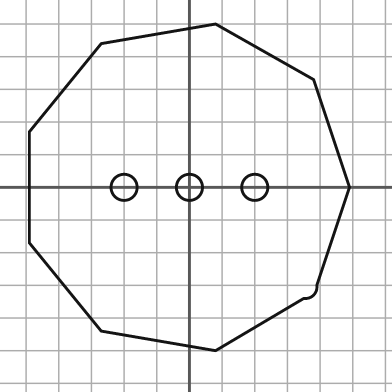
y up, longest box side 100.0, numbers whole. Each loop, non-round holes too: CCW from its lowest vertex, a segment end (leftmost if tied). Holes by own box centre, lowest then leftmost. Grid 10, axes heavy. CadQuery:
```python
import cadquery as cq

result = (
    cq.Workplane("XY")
    .moveTo(8.0, -50.0)
    .lineTo(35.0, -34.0)
    .threePointArc((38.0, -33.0), (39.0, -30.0))
    .lineTo(49.0, 0.0)
    .lineTo(38.0, 33.0)
    .lineTo(8.0, 50.0)
    .lineTo(-27.0, 44.0)
    .lineTo(-49.0, 17.0)
    .lineTo(-49.0, -17.0)
    .lineTo(-27.0, -44.0)
    .close()
    .moveTo(-20.0, 0.0)
    .circle(4.0)
    .moveTo(0.0, 0.0)
    .circle(4.0)
    .moveTo(20.0, 0.0)
    .circle(4.0)
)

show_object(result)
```